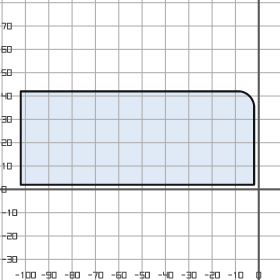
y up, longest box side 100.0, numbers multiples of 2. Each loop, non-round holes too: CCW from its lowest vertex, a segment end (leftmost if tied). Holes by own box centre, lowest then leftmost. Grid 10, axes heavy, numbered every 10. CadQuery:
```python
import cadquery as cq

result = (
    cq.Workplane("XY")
    .moveTo(-102.0, 2.0)
    .lineTo(-2.0, 2.0)
    .lineTo(-2.0, 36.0)
    .threePointArc((-4.0, 40.0), (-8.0, 42.0))
    .lineTo(-102.0, 42.0)
    .close()
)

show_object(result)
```